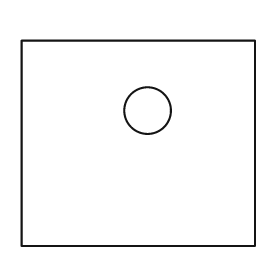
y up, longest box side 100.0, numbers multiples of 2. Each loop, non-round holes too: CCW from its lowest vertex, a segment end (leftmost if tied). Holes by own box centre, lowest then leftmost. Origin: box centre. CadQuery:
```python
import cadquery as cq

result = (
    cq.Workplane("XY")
    .moveTo(-50.0, -44.0)
    .lineTo(50.0, -44.0)
    .lineTo(50.0, 44.0)
    .lineTo(-50.0, 44.0)
    .close()
    .moveTo(4.0, 14.0)
    .circle(10.0)
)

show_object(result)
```